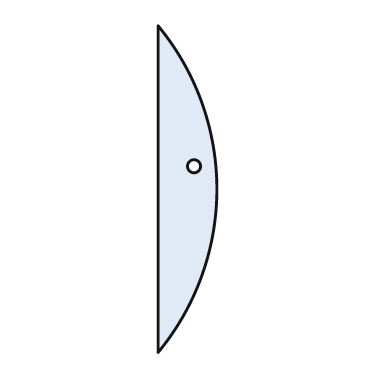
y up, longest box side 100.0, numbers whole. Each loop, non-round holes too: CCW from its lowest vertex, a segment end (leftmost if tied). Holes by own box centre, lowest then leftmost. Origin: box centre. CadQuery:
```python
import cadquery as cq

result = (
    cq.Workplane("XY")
    .moveTo(-9.0, -50.0)
    .threePointArc((9.0, 0.0), (-9.0, 50.0))
    .close()
    .moveTo(2.0, 7.0)
    .circle(2.0)
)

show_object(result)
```